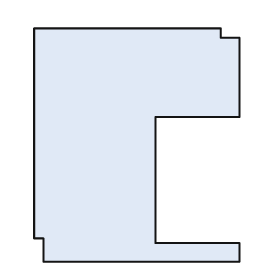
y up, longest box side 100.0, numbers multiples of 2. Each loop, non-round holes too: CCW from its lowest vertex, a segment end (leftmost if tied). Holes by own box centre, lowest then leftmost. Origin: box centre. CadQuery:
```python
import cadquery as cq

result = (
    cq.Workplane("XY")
    .moveTo(-40.0, -50.0)
    .lineTo(44.0, -50.0)
    .lineTo(44.0, -42.0)
    .lineTo(8.0, -42.0)
    .lineTo(8.0, 12.0)
    .lineTo(44.0, 12.0)
    .lineTo(44.0, 46.0)
    .lineTo(36.0, 46.0)
    .lineTo(36.0, 50.0)
    .lineTo(-44.0, 50.0)
    .lineTo(-44.0, -40.0)
    .lineTo(-40.0, -40.0)
    .close()
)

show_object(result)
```